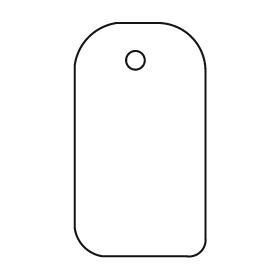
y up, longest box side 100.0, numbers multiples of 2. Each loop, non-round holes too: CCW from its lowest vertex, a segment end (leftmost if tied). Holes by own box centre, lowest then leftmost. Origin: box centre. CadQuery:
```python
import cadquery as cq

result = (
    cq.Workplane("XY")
    .moveTo(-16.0, -50.0)
    .lineTo(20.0, -50.0)
    .threePointArc((26.0, -48.0), (28.0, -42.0))
    .lineTo(28.0, 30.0)
    .threePointArc((22.0, 44.0), (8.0, 50.0))
    .lineTo(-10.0, 50.0)
    .threePointArc((-22.0, 44.0), (-28.0, 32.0))
    .lineTo(-28.0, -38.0)
    .threePointArc((-24.0, -46.0), (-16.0, -50.0))
    .close()
    .moveTo(-2.0, 34.0)
    .circle(4.0)
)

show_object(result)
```